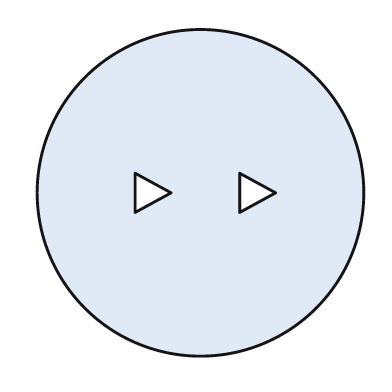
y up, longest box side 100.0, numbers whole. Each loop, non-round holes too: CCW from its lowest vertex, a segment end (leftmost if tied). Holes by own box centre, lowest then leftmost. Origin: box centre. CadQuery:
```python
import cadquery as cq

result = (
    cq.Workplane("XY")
    .moveTo(0.0, 0.0)
    .circle(50.0)
    .moveTo(-20.0, -6.0)
    .lineTo(-9.0, 0.0)
    .lineTo(-20.0, 6.0)
    .close()
    .moveTo(12.0, -6.0)
    .lineTo(23.0, 0.0)
    .lineTo(12.0, 6.0)
    .close()
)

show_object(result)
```